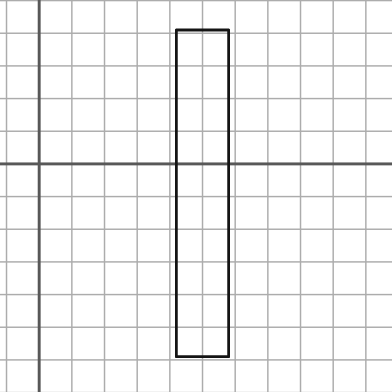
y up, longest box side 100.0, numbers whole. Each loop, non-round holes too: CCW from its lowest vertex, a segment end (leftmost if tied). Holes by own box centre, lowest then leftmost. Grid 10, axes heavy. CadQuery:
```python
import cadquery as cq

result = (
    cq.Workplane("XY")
    .moveTo(42.0, -59.0)
    .lineTo(58.0, -59.0)
    .lineTo(58.0, 41.0)
    .lineTo(42.0, 41.0)
    .close()
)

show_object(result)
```